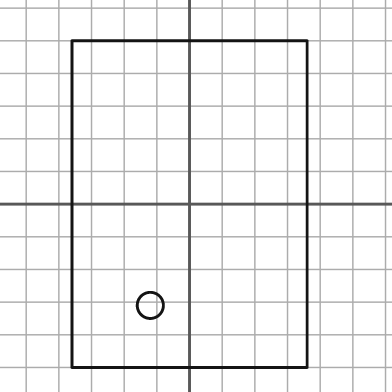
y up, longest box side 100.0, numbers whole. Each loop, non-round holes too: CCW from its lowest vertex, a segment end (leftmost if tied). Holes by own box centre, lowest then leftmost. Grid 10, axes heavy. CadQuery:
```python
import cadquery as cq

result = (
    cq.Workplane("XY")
    .moveTo(-36.0, -50.0)
    .lineTo(36.0, -50.0)
    .lineTo(36.0, 50.0)
    .lineTo(-36.0, 50.0)
    .close()
    .moveTo(-12.0, -31.0)
    .circle(4.0)
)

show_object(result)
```